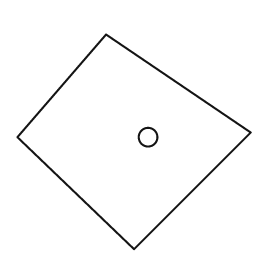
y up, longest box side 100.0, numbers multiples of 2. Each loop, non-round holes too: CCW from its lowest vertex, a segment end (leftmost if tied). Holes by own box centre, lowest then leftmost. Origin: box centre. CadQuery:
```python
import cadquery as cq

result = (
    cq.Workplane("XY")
    .moveTo(0.0, -46.0)
    .lineTo(50.0, 4.0)
    .lineTo(-12.0, 46.0)
    .lineTo(-50.0, 2.0)
    .close()
    .moveTo(6.0, 2.0)
    .circle(4.0)
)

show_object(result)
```